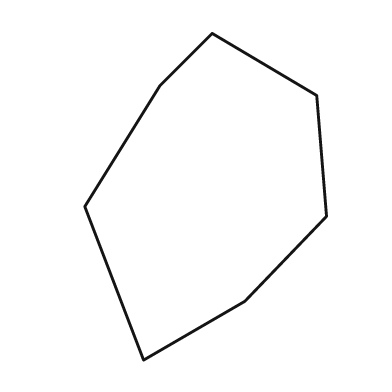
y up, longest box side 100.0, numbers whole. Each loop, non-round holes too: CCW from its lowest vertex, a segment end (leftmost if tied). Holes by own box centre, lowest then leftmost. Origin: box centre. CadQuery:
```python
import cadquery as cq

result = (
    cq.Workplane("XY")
    .moveTo(-19.0, -50.0)
    .lineTo(12.0, -32.0)
    .lineTo(37.0, -6.0)
    .lineTo(34.0, 31.0)
    .lineTo(2.0, 50.0)
    .lineTo(-14.0, 34.0)
    .lineTo(-37.0, -3.0)
    .close()
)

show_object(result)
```